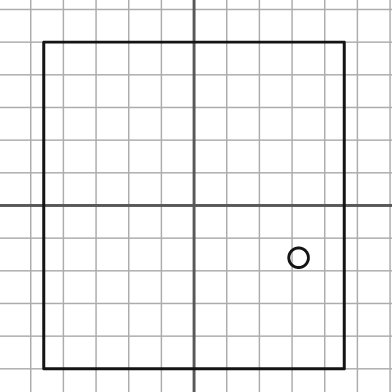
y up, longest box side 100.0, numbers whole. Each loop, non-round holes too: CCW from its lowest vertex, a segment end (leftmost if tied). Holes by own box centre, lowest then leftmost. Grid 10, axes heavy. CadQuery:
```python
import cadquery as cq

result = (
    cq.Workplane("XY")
    .moveTo(-46.0, -50.0)
    .lineTo(46.0, -50.0)
    .lineTo(46.0, 50.0)
    .lineTo(-46.0, 50.0)
    .close()
    .moveTo(32.0, -16.0)
    .circle(3.0)
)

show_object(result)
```